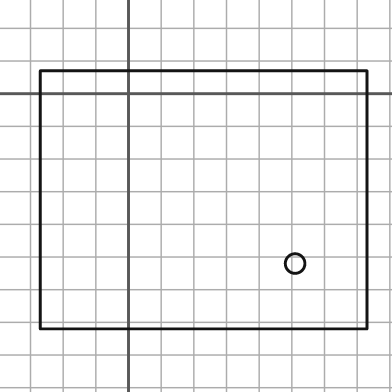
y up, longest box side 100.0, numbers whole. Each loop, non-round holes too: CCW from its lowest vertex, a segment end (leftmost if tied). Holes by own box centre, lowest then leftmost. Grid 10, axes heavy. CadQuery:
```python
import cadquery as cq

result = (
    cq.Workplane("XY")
    .moveTo(-27.0, -72.0)
    .lineTo(73.0, -72.0)
    .lineTo(73.0, 7.0)
    .lineTo(-27.0, 7.0)
    .close()
    .moveTo(51.0, -52.0)
    .circle(3.0)
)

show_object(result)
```